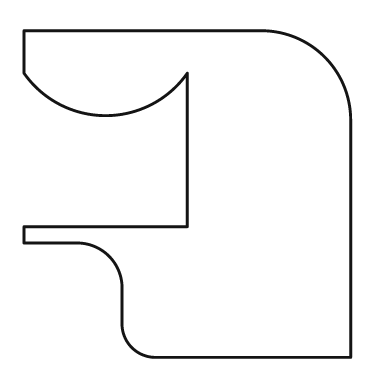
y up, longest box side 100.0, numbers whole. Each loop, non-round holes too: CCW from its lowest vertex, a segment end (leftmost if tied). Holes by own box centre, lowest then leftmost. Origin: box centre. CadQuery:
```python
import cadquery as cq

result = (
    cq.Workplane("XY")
    .moveTo(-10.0, -50.0)
    .lineTo(50.0, -50.0)
    .lineTo(50.0, 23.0)
    .threePointArc((42.0, 42.0), (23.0, 50.0))
    .lineTo(-50.0, 50.0)
    .lineTo(-50.0, 37.0)
    .threePointArc((-25.0, 24.0), (0.0, 37.0))
    .lineTo(0.0, -10.0)
    .lineTo(-50.0, -10.0)
    .lineTo(-50.0, -15.0)
    .lineTo(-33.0, -15.0)
    .threePointArc((-24.0, -19.0), (-20.0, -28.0))
    .lineTo(-20.0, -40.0)
    .threePointArc((-17.0, -47.0), (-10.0, -50.0))
    .close()
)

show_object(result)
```